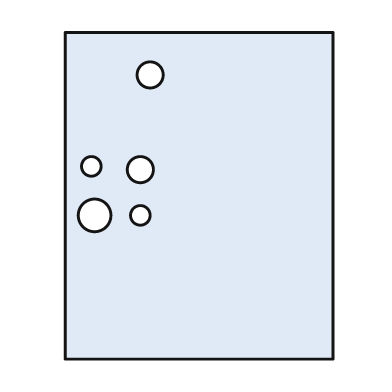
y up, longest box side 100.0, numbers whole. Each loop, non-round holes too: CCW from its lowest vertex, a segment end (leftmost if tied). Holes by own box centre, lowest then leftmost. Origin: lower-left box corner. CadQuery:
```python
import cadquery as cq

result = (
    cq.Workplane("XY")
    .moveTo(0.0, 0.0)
    .lineTo(82.0, 0.0)
    .lineTo(82.0, 100.0)
    .lineTo(0.0, 100.0)
    .close()
    .moveTo(9.0, 44.0)
    .circle(5.0)
    .moveTo(23.0, 44.0)
    .circle(3.0)
    .moveTo(23.0, 58.0)
    .circle(4.0)
    .moveTo(8.0, 59.0)
    .circle(3.0)
    .moveTo(26.0, 87.0)
    .circle(4.0)
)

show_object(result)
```